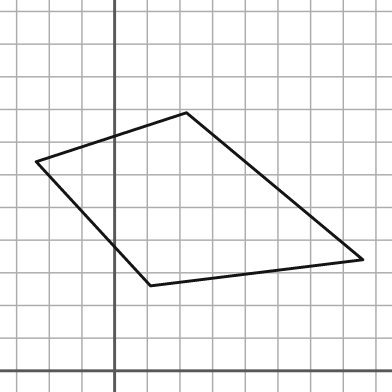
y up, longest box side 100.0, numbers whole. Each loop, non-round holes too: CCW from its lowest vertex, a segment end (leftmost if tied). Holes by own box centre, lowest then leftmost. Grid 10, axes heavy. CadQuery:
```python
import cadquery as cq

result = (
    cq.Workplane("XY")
    .moveTo(11.0, 26.0)
    .lineTo(76.0, 34.0)
    .lineTo(22.0, 79.0)
    .lineTo(-24.0, 64.0)
    .close()
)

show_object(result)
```